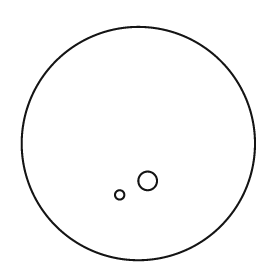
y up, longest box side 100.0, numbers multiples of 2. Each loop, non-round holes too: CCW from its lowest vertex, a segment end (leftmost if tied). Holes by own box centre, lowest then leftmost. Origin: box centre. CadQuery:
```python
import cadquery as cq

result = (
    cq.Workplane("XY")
    .moveTo(0.0, 0.0)
    .circle(50.0)
    .moveTo(-8.0, -22.0)
    .circle(2.0)
    .moveTo(4.0, -16.0)
    .circle(4.0)
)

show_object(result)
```